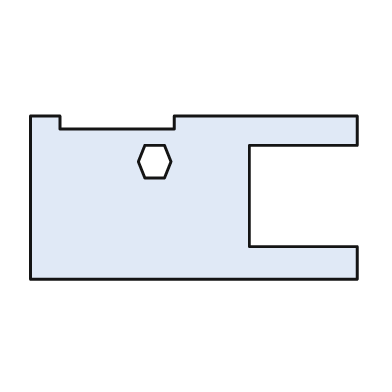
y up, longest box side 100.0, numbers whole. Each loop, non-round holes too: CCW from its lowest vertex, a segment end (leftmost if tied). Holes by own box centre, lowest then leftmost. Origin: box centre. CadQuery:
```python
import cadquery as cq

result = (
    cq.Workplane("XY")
    .moveTo(-50.0, -25.0)
    .lineTo(50.0, -25.0)
    .lineTo(50.0, -15.0)
    .lineTo(17.0, -15.0)
    .lineTo(17.0, 16.0)
    .lineTo(50.0, 16.0)
    .lineTo(50.0, 25.0)
    .lineTo(-6.0, 25.0)
    .lineTo(-6.0, 21.0)
    .lineTo(-41.0, 21.0)
    .lineTo(-41.0, 25.0)
    .lineTo(-50.0, 25.0)
    .close()
    .moveTo(-15.0, 6.0)
    .lineTo(-9.0, 6.0)
    .lineTo(-7.0, 11.0)
    .lineTo(-9.0, 16.0)
    .lineTo(-15.0, 16.0)
    .lineTo(-17.0, 11.0)
    .close()
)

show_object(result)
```